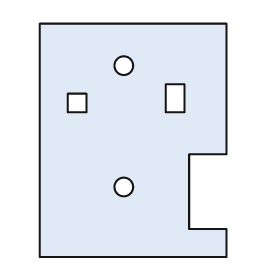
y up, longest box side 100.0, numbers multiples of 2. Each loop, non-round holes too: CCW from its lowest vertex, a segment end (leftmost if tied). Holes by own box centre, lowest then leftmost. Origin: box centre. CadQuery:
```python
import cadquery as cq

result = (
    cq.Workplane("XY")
    .moveTo(-40.0, -50.0)
    .lineTo(40.0, -50.0)
    .lineTo(40.0, -38.0)
    .lineTo(24.0, -38.0)
    .lineTo(24.0, -6.0)
    .lineTo(40.0, -6.0)
    .lineTo(40.0, 50.0)
    .lineTo(-40.0, 50.0)
    .close()
    .moveTo(-4.0, -20.0)
    .circle(4.0)
    .moveTo(-28.0, 12.0)
    .lineTo(-20.0, 12.0)
    .lineTo(-20.0, 20.0)
    .lineTo(-28.0, 20.0)
    .close()
    .moveTo(14.0, 12.0)
    .lineTo(22.0, 12.0)
    .lineTo(22.0, 24.0)
    .lineTo(14.0, 24.0)
    .close()
    .moveTo(-4.0, 32.0)
    .circle(4.0)
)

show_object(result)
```